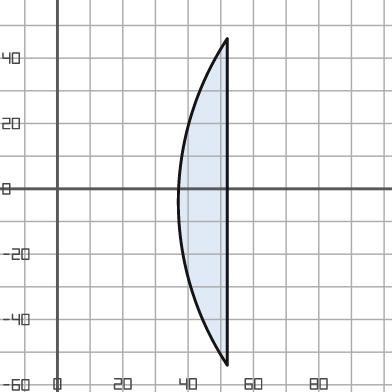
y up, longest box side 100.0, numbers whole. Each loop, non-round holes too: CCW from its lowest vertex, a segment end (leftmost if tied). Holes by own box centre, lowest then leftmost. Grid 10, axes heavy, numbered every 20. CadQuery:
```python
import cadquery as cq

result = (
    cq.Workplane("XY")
    .moveTo(52.0, -54.0)
    .lineTo(52.0, 46.0)
    .threePointArc((37.0, -4.0), (52.0, -54.0))
    .close()
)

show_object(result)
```